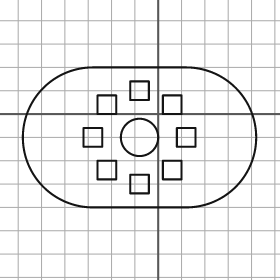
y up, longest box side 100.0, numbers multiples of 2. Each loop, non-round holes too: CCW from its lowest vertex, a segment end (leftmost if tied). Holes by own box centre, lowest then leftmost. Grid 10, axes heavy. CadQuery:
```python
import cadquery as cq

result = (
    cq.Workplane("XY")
    .moveTo(-28.0, -40.0)
    .lineTo(12.0, -40.0)
    .threePointArc((42.0, -10.0), (12.0, 20.0))
    .lineTo(-28.0, 20.0)
    .threePointArc((-58.0, -10.0), (-28.0, -40.0))
    .close()
    .moveTo(-12.0, -34.0)
    .lineTo(-4.0, -34.0)
    .lineTo(-4.0, -26.0)
    .lineTo(-12.0, -26.0)
    .close()
    .moveTo(-26.0, -28.0)
    .lineTo(-18.0, -28.0)
    .lineTo(-18.0, -20.0)
    .lineTo(-26.0, -20.0)
    .close()
    .moveTo(2.0, -28.0)
    .lineTo(10.0, -28.0)
    .lineTo(10.0, -20.0)
    .lineTo(2.0, -20.0)
    .close()
    .moveTo(-32.0, -14.0)
    .lineTo(-24.0, -14.0)
    .lineTo(-24.0, -6.0)
    .lineTo(-32.0, -6.0)
    .close()
    .moveTo(-8.0, -10.0)
    .circle(8.0)
    .moveTo(8.0, -14.0)
    .lineTo(16.0, -14.0)
    .lineTo(16.0, -6.0)
    .lineTo(8.0, -6.0)
    .close()
    .moveTo(-26.0, 0.0)
    .lineTo(-18.0, 0.0)
    .lineTo(-18.0, 8.0)
    .lineTo(-26.0, 8.0)
    .close()
    .moveTo(2.0, 0.0)
    .lineTo(10.0, 0.0)
    .lineTo(10.0, 8.0)
    .lineTo(2.0, 8.0)
    .close()
    .moveTo(-12.0, 6.0)
    .lineTo(-4.0, 6.0)
    .lineTo(-4.0, 14.0)
    .lineTo(-12.0, 14.0)
    .close()
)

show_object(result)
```